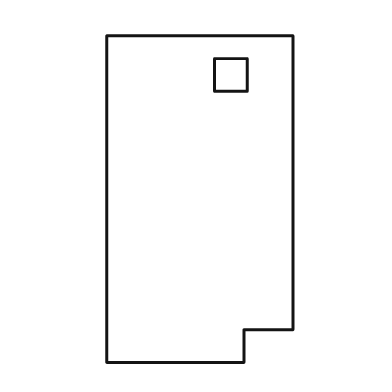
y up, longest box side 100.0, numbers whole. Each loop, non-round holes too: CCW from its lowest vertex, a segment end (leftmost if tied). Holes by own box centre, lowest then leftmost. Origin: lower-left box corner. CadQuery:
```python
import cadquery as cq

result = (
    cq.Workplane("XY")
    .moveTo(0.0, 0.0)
    .lineTo(42.0, 0.0)
    .lineTo(42.0, 10.0)
    .lineTo(57.0, 10.0)
    .lineTo(57.0, 100.0)
    .lineTo(0.0, 100.0)
    .close()
    .moveTo(33.0, 83.0)
    .lineTo(43.0, 83.0)
    .lineTo(43.0, 93.0)
    .lineTo(33.0, 93.0)
    .close()
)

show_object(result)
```